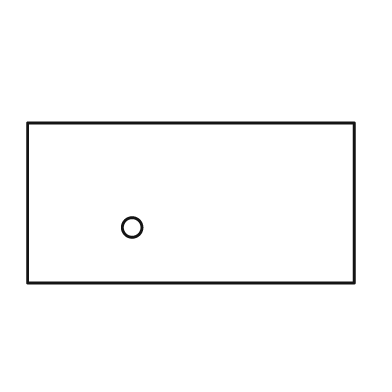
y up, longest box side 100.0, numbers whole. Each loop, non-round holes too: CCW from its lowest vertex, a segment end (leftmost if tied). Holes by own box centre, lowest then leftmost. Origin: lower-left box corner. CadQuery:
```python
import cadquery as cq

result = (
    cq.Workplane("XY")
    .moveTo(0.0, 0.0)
    .lineTo(100.0, 0.0)
    .lineTo(100.0, 49.0)
    .lineTo(0.0, 49.0)
    .close()
    .moveTo(32.0, 17.0)
    .circle(3.0)
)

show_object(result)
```